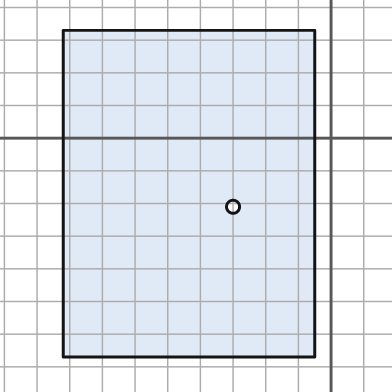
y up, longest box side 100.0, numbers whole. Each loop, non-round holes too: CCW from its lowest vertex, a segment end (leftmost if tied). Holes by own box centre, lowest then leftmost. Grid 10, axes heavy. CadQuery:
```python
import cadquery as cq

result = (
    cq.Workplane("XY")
    .moveTo(-82.0, -67.0)
    .lineTo(-5.0, -67.0)
    .lineTo(-5.0, 33.0)
    .lineTo(-82.0, 33.0)
    .close()
    .moveTo(-30.0, -21.0)
    .circle(2.0)
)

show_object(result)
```